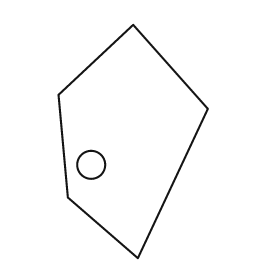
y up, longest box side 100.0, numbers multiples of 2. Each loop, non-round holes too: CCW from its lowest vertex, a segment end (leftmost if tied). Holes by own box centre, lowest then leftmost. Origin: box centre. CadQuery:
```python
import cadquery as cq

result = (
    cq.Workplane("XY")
    .moveTo(2.0, -50.0)
    .lineTo(32.0, 14.0)
    .lineTo(0.0, 50.0)
    .lineTo(-32.0, 20.0)
    .lineTo(-28.0, -24.0)
    .close()
    .moveTo(-18.0, -10.0)
    .circle(6.0)
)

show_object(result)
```